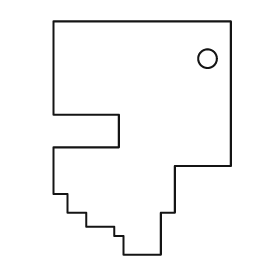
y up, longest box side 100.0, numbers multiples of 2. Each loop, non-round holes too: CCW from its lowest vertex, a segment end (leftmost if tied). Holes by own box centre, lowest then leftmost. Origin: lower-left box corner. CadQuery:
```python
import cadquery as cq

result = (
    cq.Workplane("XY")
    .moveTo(30.0, 0.0)
    .lineTo(46.0, 0.0)
    .lineTo(46.0, 18.0)
    .lineTo(52.0, 18.0)
    .lineTo(52.0, 38.0)
    .lineTo(76.0, 38.0)
    .lineTo(76.0, 100.0)
    .lineTo(0.0, 100.0)
    .lineTo(0.0, 60.0)
    .lineTo(28.0, 60.0)
    .lineTo(28.0, 46.0)
    .lineTo(0.0, 46.0)
    .lineTo(0.0, 26.0)
    .lineTo(6.0, 26.0)
    .lineTo(6.0, 18.0)
    .lineTo(14.0, 18.0)
    .lineTo(14.0, 12.0)
    .lineTo(26.0, 12.0)
    .lineTo(26.0, 8.0)
    .lineTo(30.0, 8.0)
    .close()
    .moveTo(66.0, 84.0)
    .circle(4.0)
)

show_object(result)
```